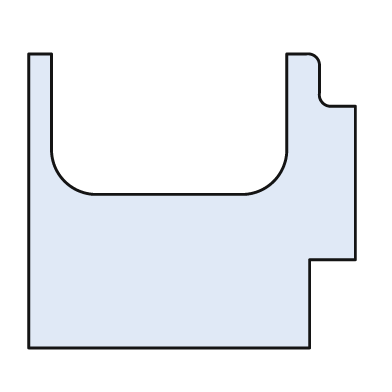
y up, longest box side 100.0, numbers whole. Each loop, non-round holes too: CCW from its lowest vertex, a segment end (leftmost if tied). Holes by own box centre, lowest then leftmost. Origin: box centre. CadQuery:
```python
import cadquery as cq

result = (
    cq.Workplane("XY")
    .moveTo(-50.0, -45.0)
    .lineTo(36.0, -45.0)
    .lineTo(36.0, -18.0)
    .lineTo(50.0, -18.0)
    .lineTo(50.0, 29.0)
    .lineTo(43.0, 29.0)
    .threePointArc((40.0, 30.0), (39.0, 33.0))
    .lineTo(39.0, 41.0)
    .threePointArc((38.0, 44.0), (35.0, 45.0))
    .lineTo(29.0, 45.0)
    .lineTo(29.0, 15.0)
    .threePointArc((25.0, 6.0), (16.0, 2.0))
    .lineTo(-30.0, 2.0)
    .threePointArc((-39.0, 6.0), (-43.0, 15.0))
    .lineTo(-43.0, 45.0)
    .lineTo(-50.0, 45.0)
    .close()
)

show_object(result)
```